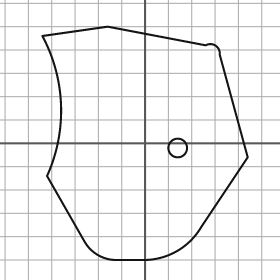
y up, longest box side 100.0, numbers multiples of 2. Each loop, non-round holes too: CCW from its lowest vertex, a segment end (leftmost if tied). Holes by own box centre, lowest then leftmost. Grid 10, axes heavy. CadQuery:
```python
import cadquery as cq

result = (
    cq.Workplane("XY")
    .moveTo(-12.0, -50.0)
    .lineTo(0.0, -50.0)
    .threePointArc((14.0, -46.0), (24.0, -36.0))
    .lineTo(44.0, -6.0)
    .lineTo(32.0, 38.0)
    .threePointArc((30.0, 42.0), (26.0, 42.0))
    .lineTo(-16.0, 50.0)
    .lineTo(-44.0, 46.0)
    .threePointArc((-36.0, 16.0), (-42.0, -14.0))
    .lineTo(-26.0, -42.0)
    .threePointArc((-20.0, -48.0), (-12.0, -50.0))
    .close()
    .moveTo(14.0, -2.0)
    .circle(4.0)
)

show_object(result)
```